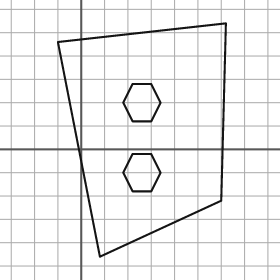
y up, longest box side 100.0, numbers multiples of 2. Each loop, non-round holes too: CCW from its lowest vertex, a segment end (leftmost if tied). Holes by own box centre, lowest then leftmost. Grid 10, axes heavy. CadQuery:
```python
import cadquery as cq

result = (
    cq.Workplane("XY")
    .moveTo(8.0, -46.0)
    .lineTo(60.0, -22.0)
    .lineTo(62.0, 54.0)
    .lineTo(-10.0, 46.0)
    .close()
    .moveTo(22.0, -18.0)
    .lineTo(30.0, -18.0)
    .lineTo(34.0, -10.0)
    .lineTo(30.0, -2.0)
    .lineTo(22.0, -2.0)
    .lineTo(18.0, -10.0)
    .close()
    .moveTo(22.0, 12.0)
    .lineTo(30.0, 12.0)
    .lineTo(34.0, 20.0)
    .lineTo(30.0, 28.0)
    .lineTo(22.0, 28.0)
    .lineTo(18.0, 20.0)
    .close()
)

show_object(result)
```